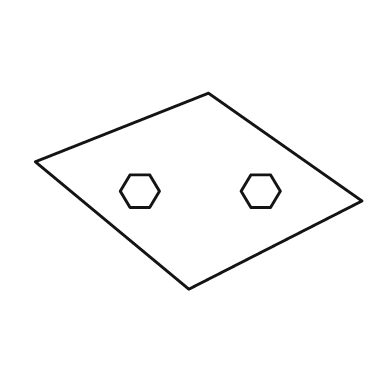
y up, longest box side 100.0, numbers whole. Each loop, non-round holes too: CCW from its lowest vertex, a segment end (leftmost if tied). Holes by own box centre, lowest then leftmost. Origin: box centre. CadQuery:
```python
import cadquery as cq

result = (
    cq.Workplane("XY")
    .moveTo(-3.0, -30.0)
    .lineTo(50.0, -3.0)
    .lineTo(3.0, 30.0)
    .lineTo(-50.0, 9.0)
    .close()
    .moveTo(-21.0, -5.0)
    .lineTo(-15.0, -5.0)
    .lineTo(-12.0, 0.0)
    .lineTo(-15.0, 5.0)
    .lineTo(-21.0, 5.0)
    .lineTo(-24.0, 0.0)
    .close()
    .moveTo(16.0, -5.0)
    .lineTo(22.0, -5.0)
    .lineTo(25.0, 0.0)
    .lineTo(22.0, 5.0)
    .lineTo(16.0, 5.0)
    .lineTo(13.0, 0.0)
    .close()
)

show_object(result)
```